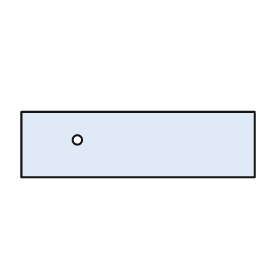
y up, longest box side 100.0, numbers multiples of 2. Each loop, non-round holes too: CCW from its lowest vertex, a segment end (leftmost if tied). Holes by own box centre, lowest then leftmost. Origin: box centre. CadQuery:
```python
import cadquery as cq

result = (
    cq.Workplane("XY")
    .moveTo(-50.0, -14.0)
    .lineTo(50.0, -14.0)
    .lineTo(50.0, 14.0)
    .lineTo(-50.0, 14.0)
    .close()
    .moveTo(-26.0, 2.0)
    .circle(2.0)
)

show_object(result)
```